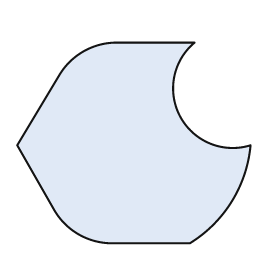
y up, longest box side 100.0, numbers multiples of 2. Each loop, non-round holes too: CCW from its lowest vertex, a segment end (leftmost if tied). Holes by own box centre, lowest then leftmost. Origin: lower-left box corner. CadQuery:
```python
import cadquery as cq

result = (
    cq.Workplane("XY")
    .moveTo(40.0, 0.0)
    .lineTo(74.0, 0.0)
    .threePointArc((92.0, 18.0), (100.0, 42.0))
    .threePointArc((70.0, 54.0), (76.0, 86.0))
    .lineTo(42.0, 86.0)
    .threePointArc((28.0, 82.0), (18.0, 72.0))
    .lineTo(0.0, 42.0)
    .lineTo(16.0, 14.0)
    .threePointArc((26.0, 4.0), (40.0, 0.0))
    .close()
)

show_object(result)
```